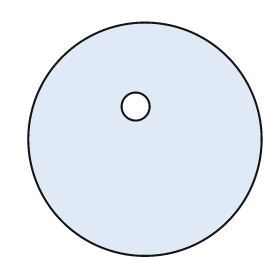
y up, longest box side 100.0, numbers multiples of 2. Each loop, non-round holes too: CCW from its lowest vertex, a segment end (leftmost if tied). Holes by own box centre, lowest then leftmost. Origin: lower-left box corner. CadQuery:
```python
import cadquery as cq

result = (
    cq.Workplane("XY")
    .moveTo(50.0, 50.0)
    .circle(50.0)
    .moveTo(46.0, 64.0)
    .circle(6.0)
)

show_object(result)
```